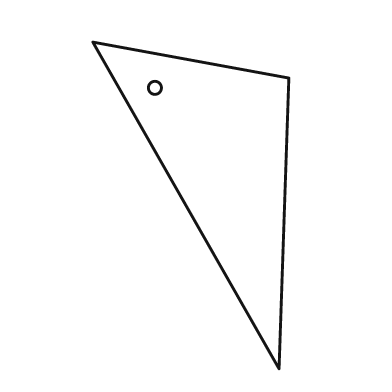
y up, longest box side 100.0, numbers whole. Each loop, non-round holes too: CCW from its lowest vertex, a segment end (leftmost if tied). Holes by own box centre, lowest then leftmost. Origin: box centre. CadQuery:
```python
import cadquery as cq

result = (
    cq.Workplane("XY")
    .moveTo(27.0, -50.0)
    .lineTo(30.0, 39.0)
    .lineTo(-30.0, 50.0)
    .close()
    .moveTo(-11.0, 36.0)
    .circle(2.0)
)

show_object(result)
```